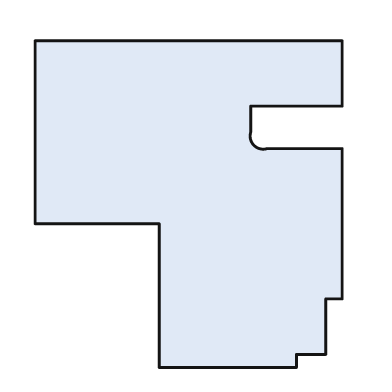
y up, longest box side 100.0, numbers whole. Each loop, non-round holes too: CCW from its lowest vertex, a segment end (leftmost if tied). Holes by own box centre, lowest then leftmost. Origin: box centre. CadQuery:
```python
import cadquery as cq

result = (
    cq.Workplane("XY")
    .moveTo(-9.0, -50.0)
    .lineTo(33.0, -50.0)
    .lineTo(33.0, -46.0)
    .lineTo(42.0, -46.0)
    .lineTo(42.0, -29.0)
    .lineTo(47.0, -29.0)
    .lineTo(47.0, 17.0)
    .lineTo(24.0, 17.0)
    .threePointArc((20.0, 18.0), (19.0, 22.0))
    .lineTo(19.0, 30.0)
    .lineTo(47.0, 30.0)
    .lineTo(47.0, 50.0)
    .lineTo(-47.0, 50.0)
    .lineTo(-47.0, -6.0)
    .lineTo(-9.0, -6.0)
    .close()
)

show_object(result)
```